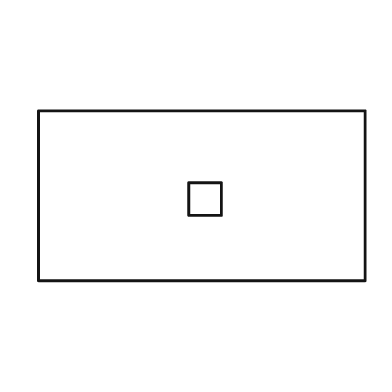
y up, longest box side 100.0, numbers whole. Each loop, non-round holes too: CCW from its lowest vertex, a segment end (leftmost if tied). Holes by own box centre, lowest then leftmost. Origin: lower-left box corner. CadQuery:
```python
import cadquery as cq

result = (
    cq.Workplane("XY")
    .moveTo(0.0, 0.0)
    .lineTo(100.0, 0.0)
    .lineTo(100.0, 52.0)
    .lineTo(0.0, 52.0)
    .close()
    .moveTo(46.0, 20.0)
    .lineTo(56.0, 20.0)
    .lineTo(56.0, 30.0)
    .lineTo(46.0, 30.0)
    .close()
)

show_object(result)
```